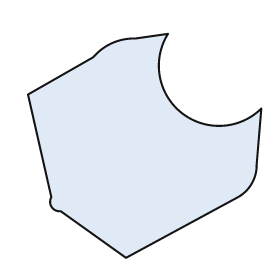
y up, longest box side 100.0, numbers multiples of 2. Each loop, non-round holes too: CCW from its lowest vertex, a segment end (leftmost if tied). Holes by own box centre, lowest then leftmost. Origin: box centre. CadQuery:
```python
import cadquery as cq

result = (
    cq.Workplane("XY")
    .moveTo(-8.0, -48.0)
    .lineTo(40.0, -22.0)
    .threePointArc((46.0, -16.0), (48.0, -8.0))
    .lineTo(50.0, 16.0)
    .threePointArc((16.0, 14.0), (10.0, 48.0))
    .lineTo(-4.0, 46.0)
    .threePointArc((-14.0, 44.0), (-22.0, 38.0))
    .lineTo(-50.0, 22.0)
    .lineTo(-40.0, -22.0)
    .threePointArc((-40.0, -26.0), (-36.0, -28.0))
    .close()
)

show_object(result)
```